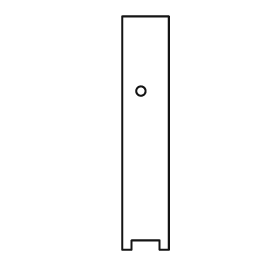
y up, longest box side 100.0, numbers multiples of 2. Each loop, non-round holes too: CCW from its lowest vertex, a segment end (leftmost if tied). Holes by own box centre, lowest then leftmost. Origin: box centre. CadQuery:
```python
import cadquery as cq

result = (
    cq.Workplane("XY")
    .moveTo(-10.0, -50.0)
    .lineTo(-6.0, -50.0)
    .lineTo(-6.0, -46.0)
    .lineTo(6.0, -46.0)
    .lineTo(6.0, -50.0)
    .lineTo(10.0, -50.0)
    .lineTo(10.0, 50.0)
    .lineTo(-10.0, 50.0)
    .close()
    .moveTo(-2.0, 18.0)
    .circle(2.0)
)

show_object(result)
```